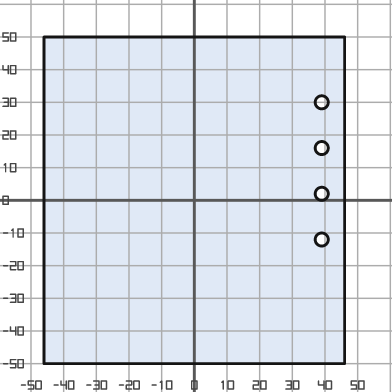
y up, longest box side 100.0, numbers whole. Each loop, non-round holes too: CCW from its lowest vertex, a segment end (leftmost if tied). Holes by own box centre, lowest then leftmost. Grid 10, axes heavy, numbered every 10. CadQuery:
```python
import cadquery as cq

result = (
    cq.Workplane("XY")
    .moveTo(-46.0, -50.0)
    .lineTo(46.0, -50.0)
    .lineTo(46.0, 50.0)
    .lineTo(-46.0, 50.0)
    .close()
    .moveTo(39.0, -12.0)
    .circle(2.0)
    .moveTo(39.0, 2.0)
    .circle(2.0)
    .moveTo(39.0, 16.0)
    .circle(2.0)
    .moveTo(39.0, 30.0)
    .circle(2.0)
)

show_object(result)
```